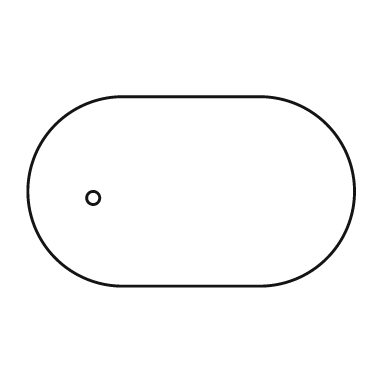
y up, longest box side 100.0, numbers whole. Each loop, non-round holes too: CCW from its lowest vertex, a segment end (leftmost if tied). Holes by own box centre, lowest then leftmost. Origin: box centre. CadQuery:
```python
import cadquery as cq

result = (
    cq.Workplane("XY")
    .moveTo(-21.0, -29.0)
    .lineTo(21.0, -29.0)
    .threePointArc((50.0, 0.0), (21.0, 29.0))
    .lineTo(-21.0, 29.0)
    .threePointArc((-50.0, 0.0), (-21.0, -29.0))
    .close()
    .moveTo(-30.0, -2.0)
    .circle(2.0)
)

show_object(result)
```